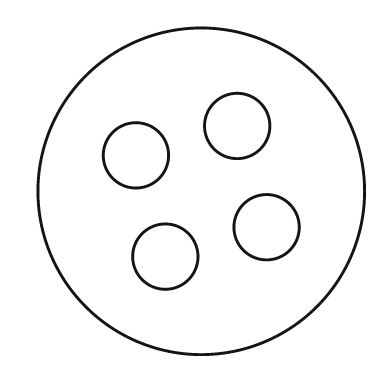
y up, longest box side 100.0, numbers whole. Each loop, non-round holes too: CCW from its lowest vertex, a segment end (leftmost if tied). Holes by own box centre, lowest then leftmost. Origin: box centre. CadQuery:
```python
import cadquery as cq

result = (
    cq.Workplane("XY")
    .moveTo(0.0, 0.0)
    .circle(50.0)
    .moveTo(-11.0, -20.0)
    .circle(10.0)
    .moveTo(20.0, -11.0)
    .circle(10.0)
    .moveTo(-20.0, 11.0)
    .circle(10.0)
    .moveTo(11.0, 20.0)
    .circle(10.0)
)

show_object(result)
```